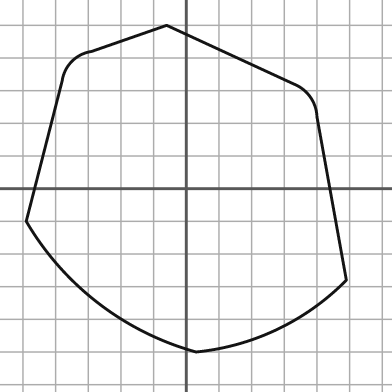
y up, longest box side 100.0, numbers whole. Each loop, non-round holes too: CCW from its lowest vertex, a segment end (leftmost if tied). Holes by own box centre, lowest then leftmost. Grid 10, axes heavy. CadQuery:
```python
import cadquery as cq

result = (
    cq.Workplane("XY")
    .moveTo(3.0, -50.0)
    .threePointArc((28.0, -43.0), (49.0, -28.0))
    .lineTo(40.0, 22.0)
    .threePointArc((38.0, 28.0), (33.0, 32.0))
    .lineTo(-6.0, 50.0)
    .lineTo(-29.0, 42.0)
    .threePointArc((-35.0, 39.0), (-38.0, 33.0))
    .lineTo(-49.0, -10.0)
    .threePointArc((-27.0, -35.0), (3.0, -50.0))
    .close()
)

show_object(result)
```